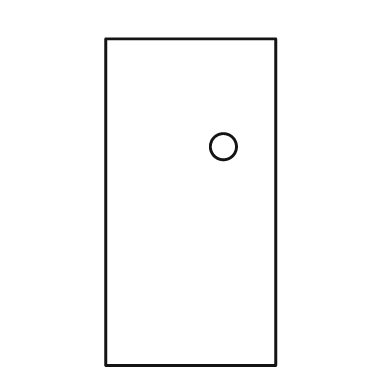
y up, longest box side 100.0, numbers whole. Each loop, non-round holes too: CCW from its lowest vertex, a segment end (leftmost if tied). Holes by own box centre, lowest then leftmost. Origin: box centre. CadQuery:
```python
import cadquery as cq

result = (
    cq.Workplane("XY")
    .moveTo(-26.0, -50.0)
    .lineTo(26.0, -50.0)
    .lineTo(26.0, 50.0)
    .lineTo(-26.0, 50.0)
    .close()
    .moveTo(10.0, 17.0)
    .circle(4.0)
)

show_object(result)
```